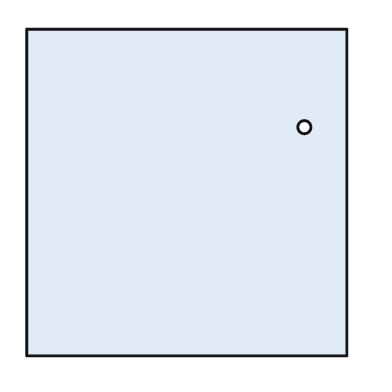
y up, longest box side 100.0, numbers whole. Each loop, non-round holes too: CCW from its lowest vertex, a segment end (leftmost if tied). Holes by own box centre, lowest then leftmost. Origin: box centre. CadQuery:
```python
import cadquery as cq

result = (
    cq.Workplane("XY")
    .moveTo(-49.0, -50.0)
    .lineTo(49.0, -50.0)
    .lineTo(49.0, 50.0)
    .lineTo(-49.0, 50.0)
    .close()
    .moveTo(36.0, 20.0)
    .circle(2.0)
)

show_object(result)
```